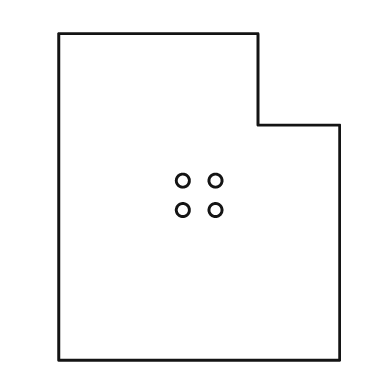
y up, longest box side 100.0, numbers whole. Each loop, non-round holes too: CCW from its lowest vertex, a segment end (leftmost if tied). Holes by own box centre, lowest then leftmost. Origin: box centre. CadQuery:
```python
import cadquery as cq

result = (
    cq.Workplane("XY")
    .moveTo(-43.0, -50.0)
    .lineTo(43.0, -50.0)
    .lineTo(43.0, 22.0)
    .lineTo(18.0, 22.0)
    .lineTo(18.0, 50.0)
    .lineTo(-43.0, 50.0)
    .close()
    .moveTo(-5.0, -4.0)
    .circle(2.0)
    .moveTo(5.0, -4.0)
    .circle(2.0)
    .moveTo(-5.0, 5.0)
    .circle(2.0)
    .moveTo(5.0, 5.0)
    .circle(2.0)
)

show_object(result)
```